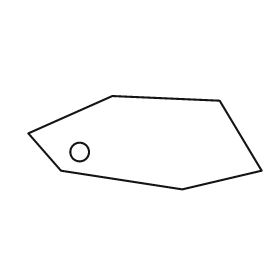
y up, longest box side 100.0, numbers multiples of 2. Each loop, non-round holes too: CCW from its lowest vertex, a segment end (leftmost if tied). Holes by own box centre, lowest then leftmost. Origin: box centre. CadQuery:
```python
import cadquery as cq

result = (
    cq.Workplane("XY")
    .moveTo(16.0, -20.0)
    .lineTo(50.0, -12.0)
    .lineTo(32.0, 18.0)
    .lineTo(-14.0, 20.0)
    .lineTo(-50.0, 4.0)
    .lineTo(-36.0, -12.0)
    .close()
    .moveTo(-28.0, -4.0)
    .circle(4.0)
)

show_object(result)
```